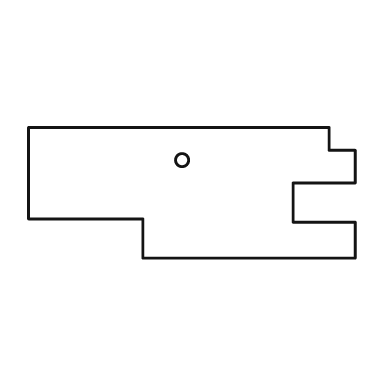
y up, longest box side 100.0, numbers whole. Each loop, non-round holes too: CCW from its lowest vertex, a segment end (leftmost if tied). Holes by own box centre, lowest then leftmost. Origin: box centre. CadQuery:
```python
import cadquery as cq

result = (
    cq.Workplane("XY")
    .moveTo(-15.0, -20.0)
    .lineTo(50.0, -20.0)
    .lineTo(50.0, -9.0)
    .lineTo(31.0, -9.0)
    .lineTo(31.0, 3.0)
    .lineTo(50.0, 3.0)
    .lineTo(50.0, 13.0)
    .lineTo(42.0, 13.0)
    .lineTo(42.0, 20.0)
    .lineTo(-50.0, 20.0)
    .lineTo(-50.0, -8.0)
    .lineTo(-15.0, -8.0)
    .close()
    .moveTo(-3.0, 10.0)
    .circle(2.0)
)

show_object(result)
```